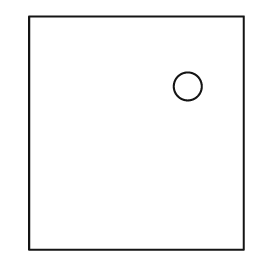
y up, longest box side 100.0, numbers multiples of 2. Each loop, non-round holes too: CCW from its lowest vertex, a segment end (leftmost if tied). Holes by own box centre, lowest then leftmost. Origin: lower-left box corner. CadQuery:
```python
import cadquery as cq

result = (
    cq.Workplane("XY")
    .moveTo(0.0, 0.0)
    .lineTo(92.0, 0.0)
    .lineTo(92.0, 100.0)
    .lineTo(0.0, 100.0)
    .close()
    .moveTo(68.0, 70.0)
    .circle(6.0)
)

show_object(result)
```